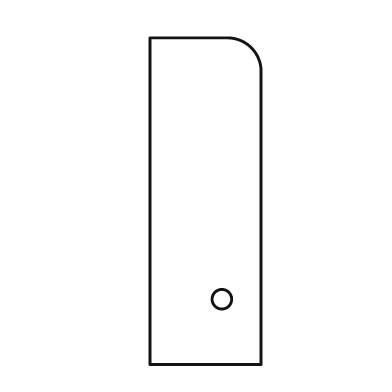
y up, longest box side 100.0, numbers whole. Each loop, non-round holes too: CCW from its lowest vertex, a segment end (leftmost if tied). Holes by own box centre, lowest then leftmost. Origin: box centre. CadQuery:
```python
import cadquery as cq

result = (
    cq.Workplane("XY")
    .moveTo(-17.0, -50.0)
    .lineTo(17.0, -50.0)
    .lineTo(17.0, 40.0)
    .threePointArc((14.0, 47.0), (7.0, 50.0))
    .lineTo(-17.0, 50.0)
    .close()
    .moveTo(5.0, -30.0)
    .circle(3.0)
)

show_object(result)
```